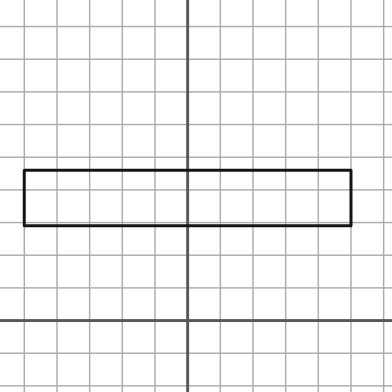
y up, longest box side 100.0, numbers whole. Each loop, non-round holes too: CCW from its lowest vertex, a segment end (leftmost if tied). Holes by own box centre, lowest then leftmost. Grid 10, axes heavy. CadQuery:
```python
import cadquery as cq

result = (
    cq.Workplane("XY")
    .moveTo(-50.0, 29.0)
    .lineTo(50.0, 29.0)
    .lineTo(50.0, 46.0)
    .lineTo(-50.0, 46.0)
    .close()
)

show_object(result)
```